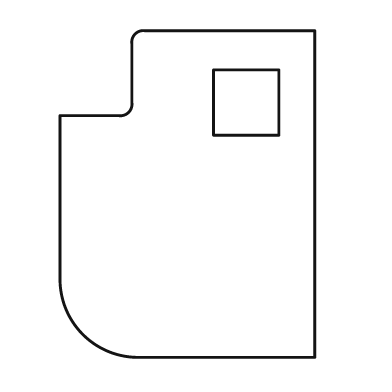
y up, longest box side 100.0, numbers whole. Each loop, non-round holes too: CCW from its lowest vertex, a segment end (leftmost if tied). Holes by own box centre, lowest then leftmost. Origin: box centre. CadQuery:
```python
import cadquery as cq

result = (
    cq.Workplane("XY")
    .moveTo(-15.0, -50.0)
    .lineTo(39.0, -50.0)
    .lineTo(39.0, 50.0)
    .lineTo(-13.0, 50.0)
    .threePointArc((-16.0, 49.0), (-17.0, 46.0))
    .lineTo(-17.0, 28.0)
    .threePointArc((-18.0, 25.0), (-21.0, 24.0))
    .lineTo(-39.0, 24.0)
    .lineTo(-39.0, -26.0)
    .threePointArc((-32.0, -43.0), (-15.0, -50.0))
    .close()
    .moveTo(8.0, 18.0)
    .lineTo(28.0, 18.0)
    .lineTo(28.0, 38.0)
    .lineTo(8.0, 38.0)
    .close()
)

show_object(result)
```